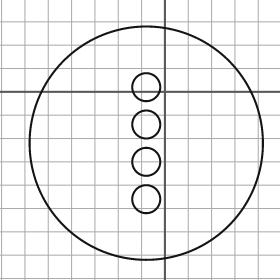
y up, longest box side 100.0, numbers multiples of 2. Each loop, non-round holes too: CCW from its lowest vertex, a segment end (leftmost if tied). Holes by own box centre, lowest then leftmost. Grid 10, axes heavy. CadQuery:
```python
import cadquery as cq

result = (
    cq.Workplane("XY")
    .moveTo(-8.0, -22.0)
    .circle(50.0)
    .moveTo(-8.0, -46.0)
    .circle(6.0)
    .moveTo(-8.0, -30.0)
    .circle(6.0)
    .moveTo(-8.0, -14.0)
    .circle(6.0)
    .moveTo(-8.0, 2.0)
    .circle(6.0)
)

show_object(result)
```